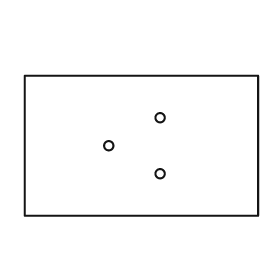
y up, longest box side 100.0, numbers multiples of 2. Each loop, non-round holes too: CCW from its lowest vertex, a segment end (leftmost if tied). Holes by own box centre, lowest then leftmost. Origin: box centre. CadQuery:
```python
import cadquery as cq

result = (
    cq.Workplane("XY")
    .moveTo(-50.0, -30.0)
    .lineTo(50.0, -30.0)
    .lineTo(50.0, 30.0)
    .lineTo(-50.0, 30.0)
    .close()
    .moveTo(8.0, -12.0)
    .circle(2.0)
    .moveTo(-14.0, 0.0)
    .circle(2.0)
    .moveTo(8.0, 12.0)
    .circle(2.0)
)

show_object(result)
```